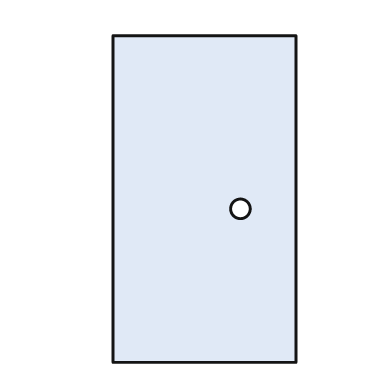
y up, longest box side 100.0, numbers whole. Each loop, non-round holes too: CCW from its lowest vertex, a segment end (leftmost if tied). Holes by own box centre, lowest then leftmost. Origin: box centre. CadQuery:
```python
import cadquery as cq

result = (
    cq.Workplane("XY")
    .moveTo(-28.0, -50.0)
    .lineTo(28.0, -50.0)
    .lineTo(28.0, 50.0)
    .lineTo(-28.0, 50.0)
    .close()
    .moveTo(11.0, -3.0)
    .circle(3.0)
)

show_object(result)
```